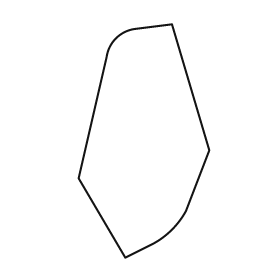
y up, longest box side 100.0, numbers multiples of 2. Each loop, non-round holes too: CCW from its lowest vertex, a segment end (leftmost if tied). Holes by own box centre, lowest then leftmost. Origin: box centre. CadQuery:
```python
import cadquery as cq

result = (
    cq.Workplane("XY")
    .moveTo(-8.0, -50.0)
    .lineTo(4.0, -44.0)
    .threePointArc((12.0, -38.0), (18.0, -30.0))
    .lineTo(28.0, -4.0)
    .lineTo(12.0, 50.0)
    .lineTo(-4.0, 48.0)
    .threePointArc((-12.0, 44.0), (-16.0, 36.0))
    .lineTo(-28.0, -16.0)
    .close()
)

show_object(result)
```